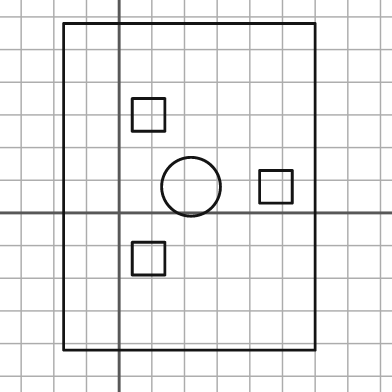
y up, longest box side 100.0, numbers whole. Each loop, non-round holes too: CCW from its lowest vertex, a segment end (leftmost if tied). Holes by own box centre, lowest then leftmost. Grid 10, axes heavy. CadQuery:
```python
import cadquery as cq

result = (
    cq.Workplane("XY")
    .moveTo(-17.0, -42.0)
    .lineTo(60.0, -42.0)
    .lineTo(60.0, 58.0)
    .lineTo(-17.0, 58.0)
    .close()
    .moveTo(4.0, -19.0)
    .lineTo(14.0, -19.0)
    .lineTo(14.0, -9.0)
    .lineTo(4.0, -9.0)
    .close()
    .moveTo(22.0, 8.0)
    .circle(9.0)
    .moveTo(43.0, 3.0)
    .lineTo(53.0, 3.0)
    .lineTo(53.0, 13.0)
    .lineTo(43.0, 13.0)
    .close()
    .moveTo(4.0, 25.0)
    .lineTo(14.0, 25.0)
    .lineTo(14.0, 35.0)
    .lineTo(4.0, 35.0)
    .close()
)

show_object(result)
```